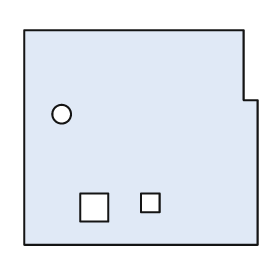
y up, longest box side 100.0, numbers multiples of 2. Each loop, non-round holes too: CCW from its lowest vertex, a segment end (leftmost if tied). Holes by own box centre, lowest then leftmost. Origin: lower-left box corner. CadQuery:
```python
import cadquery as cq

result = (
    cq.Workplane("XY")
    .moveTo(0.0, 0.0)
    .lineTo(100.0, 0.0)
    .lineTo(100.0, 62.0)
    .lineTo(94.0, 62.0)
    .lineTo(94.0, 92.0)
    .lineTo(0.0, 92.0)
    .close()
    .moveTo(24.0, 10.0)
    .lineTo(36.0, 10.0)
    .lineTo(36.0, 22.0)
    .lineTo(24.0, 22.0)
    .close()
    .moveTo(50.0, 14.0)
    .lineTo(58.0, 14.0)
    .lineTo(58.0, 22.0)
    .lineTo(50.0, 22.0)
    .close()
    .moveTo(16.0, 56.0)
    .circle(4.0)
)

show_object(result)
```